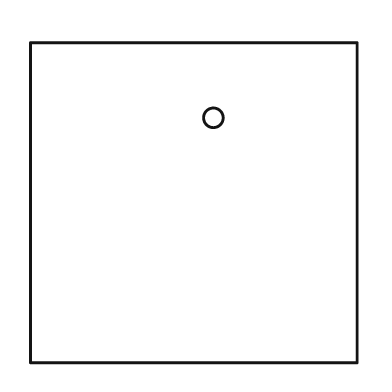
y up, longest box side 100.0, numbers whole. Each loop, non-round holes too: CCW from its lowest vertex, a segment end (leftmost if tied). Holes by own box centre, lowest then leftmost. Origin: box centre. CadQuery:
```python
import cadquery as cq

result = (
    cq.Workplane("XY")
    .moveTo(-50.0, -49.0)
    .lineTo(50.0, -49.0)
    .lineTo(50.0, 49.0)
    .lineTo(-50.0, 49.0)
    .close()
    .moveTo(6.0, 26.0)
    .circle(3.0)
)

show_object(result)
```